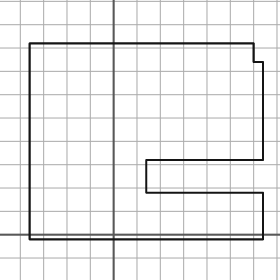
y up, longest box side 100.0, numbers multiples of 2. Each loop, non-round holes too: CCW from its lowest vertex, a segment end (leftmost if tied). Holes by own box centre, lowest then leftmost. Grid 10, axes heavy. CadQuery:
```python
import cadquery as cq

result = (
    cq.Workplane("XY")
    .moveTo(-36.0, -2.0)
    .lineTo(64.0, -2.0)
    .lineTo(64.0, 18.0)
    .lineTo(14.0, 18.0)
    .lineTo(14.0, 32.0)
    .lineTo(64.0, 32.0)
    .lineTo(64.0, 74.0)
    .lineTo(60.0, 74.0)
    .lineTo(60.0, 82.0)
    .lineTo(-36.0, 82.0)
    .close()
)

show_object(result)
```